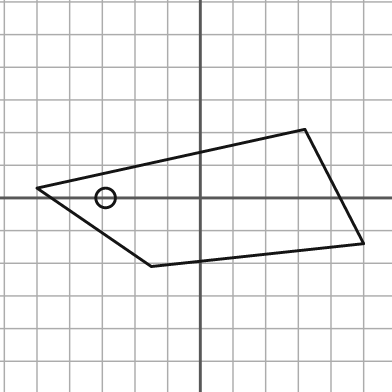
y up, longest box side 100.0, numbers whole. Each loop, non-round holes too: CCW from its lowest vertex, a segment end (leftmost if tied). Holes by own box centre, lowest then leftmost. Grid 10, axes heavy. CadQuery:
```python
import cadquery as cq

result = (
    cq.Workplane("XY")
    .moveTo(-15.0, -21.0)
    .lineTo(50.0, -14.0)
    .lineTo(32.0, 21.0)
    .lineTo(-50.0, 3.0)
    .close()
    .moveTo(-29.0, 0.0)
    .circle(3.0)
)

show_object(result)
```